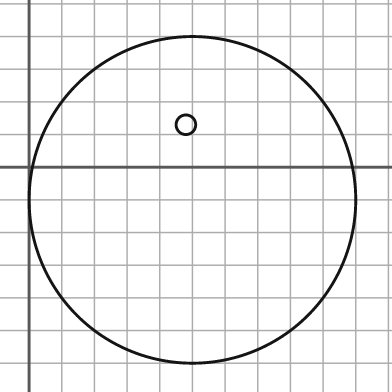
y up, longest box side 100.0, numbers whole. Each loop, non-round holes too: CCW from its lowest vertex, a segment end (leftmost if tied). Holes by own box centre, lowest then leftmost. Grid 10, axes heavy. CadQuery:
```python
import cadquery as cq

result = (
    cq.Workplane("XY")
    .moveTo(50.0, -10.0)
    .circle(50.0)
    .moveTo(48.0, 13.0)
    .circle(3.0)
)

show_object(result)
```